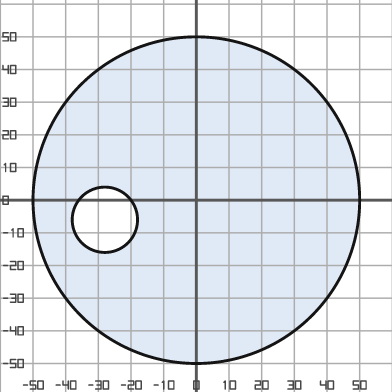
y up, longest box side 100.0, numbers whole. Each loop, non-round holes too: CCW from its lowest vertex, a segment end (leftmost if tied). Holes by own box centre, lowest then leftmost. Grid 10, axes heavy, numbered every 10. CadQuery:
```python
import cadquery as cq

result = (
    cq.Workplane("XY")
    .moveTo(0.0, 0.0)
    .circle(50.0)
    .moveTo(-28.0, -6.0)
    .circle(10.0)
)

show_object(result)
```